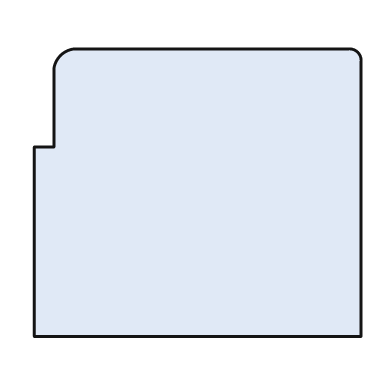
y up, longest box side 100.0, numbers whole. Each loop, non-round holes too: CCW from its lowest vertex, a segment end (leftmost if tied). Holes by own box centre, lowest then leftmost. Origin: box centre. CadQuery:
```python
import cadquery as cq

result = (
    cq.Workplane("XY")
    .moveTo(-50.0, -44.0)
    .lineTo(50.0, -44.0)
    .lineTo(50.0, 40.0)
    .threePointArc((49.0, 43.0), (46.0, 44.0))
    .lineTo(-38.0, 44.0)
    .threePointArc((-42.0, 42.0), (-44.0, 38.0))
    .lineTo(-44.0, 14.0)
    .lineTo(-50.0, 14.0)
    .close()
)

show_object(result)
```